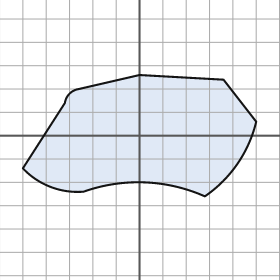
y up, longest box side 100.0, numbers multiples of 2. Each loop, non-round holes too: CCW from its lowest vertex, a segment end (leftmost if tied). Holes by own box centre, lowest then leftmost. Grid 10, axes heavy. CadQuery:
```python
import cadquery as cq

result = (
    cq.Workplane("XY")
    .moveTo(28.0, -26.0)
    .threePointArc((42.0, -12.0), (50.0, 6.0))
    .lineTo(36.0, 24.0)
    .lineTo(0.0, 26.0)
    .lineTo(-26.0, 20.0)
    .threePointArc((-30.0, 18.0), (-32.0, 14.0))
    .lineTo(-50.0, -14.0)
    .threePointArc((-38.0, -22.0), (-24.0, -24.0))
    .threePointArc((2.0, -20.0), (28.0, -26.0))
    .close()
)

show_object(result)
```